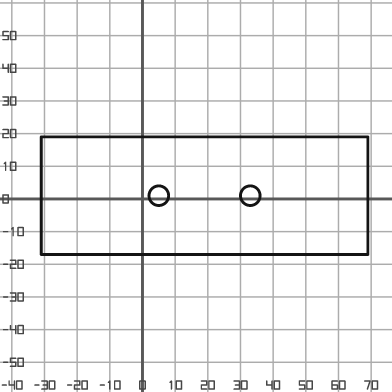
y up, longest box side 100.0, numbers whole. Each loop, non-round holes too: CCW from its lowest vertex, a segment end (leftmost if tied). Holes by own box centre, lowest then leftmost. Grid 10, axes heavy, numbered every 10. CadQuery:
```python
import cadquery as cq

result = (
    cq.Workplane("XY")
    .moveTo(-31.0, -17.0)
    .lineTo(69.0, -17.0)
    .lineTo(69.0, 19.0)
    .lineTo(-31.0, 19.0)
    .close()
    .moveTo(5.0, 1.0)
    .circle(3.0)
    .moveTo(33.0, 1.0)
    .circle(3.0)
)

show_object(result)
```